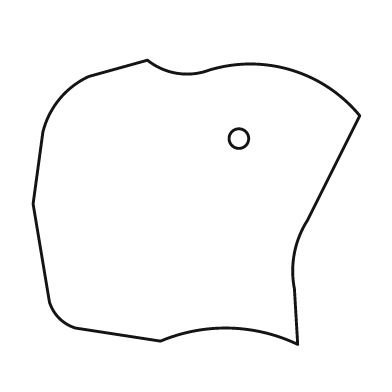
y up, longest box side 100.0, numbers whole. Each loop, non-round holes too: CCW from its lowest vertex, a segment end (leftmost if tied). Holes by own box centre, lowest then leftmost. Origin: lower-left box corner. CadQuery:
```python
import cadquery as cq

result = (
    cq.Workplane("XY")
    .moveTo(81.0, 0.0)
    .lineTo(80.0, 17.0)
    .threePointArc((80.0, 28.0), (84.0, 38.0))
    .lineTo(100.0, 70.0)
    .threePointArc((79.0, 84.0), (54.0, 84.0))
    .threePointArc((44.0, 83.0), (35.0, 87.0))
    .lineTo(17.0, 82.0)
    .threePointArc((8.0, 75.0), (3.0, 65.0))
    .lineTo(0.0, 43.0)
    .lineTo(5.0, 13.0)
    .threePointArc((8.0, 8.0), (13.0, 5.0))
    .lineTo(39.0, 1.0)
    .threePointArc((60.0, 5.0), (81.0, 0.0))
    .close()
    .moveTo(63.0, 63.0)
    .circle(3.0)
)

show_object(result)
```